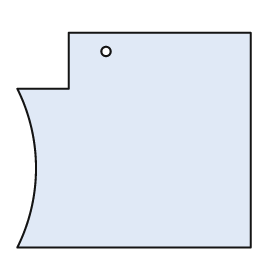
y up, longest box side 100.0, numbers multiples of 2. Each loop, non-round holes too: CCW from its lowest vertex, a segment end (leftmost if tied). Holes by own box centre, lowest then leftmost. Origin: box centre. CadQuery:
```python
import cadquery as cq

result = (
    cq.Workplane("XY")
    .moveTo(-50.0, -46.0)
    .lineTo(50.0, -46.0)
    .lineTo(50.0, 46.0)
    .lineTo(-28.0, 46.0)
    .lineTo(-28.0, 22.0)
    .lineTo(-50.0, 22.0)
    .threePointArc((-42.0, -12.0), (-50.0, -46.0))
    .close()
    .moveTo(-12.0, 38.0)
    .circle(2.0)
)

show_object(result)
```